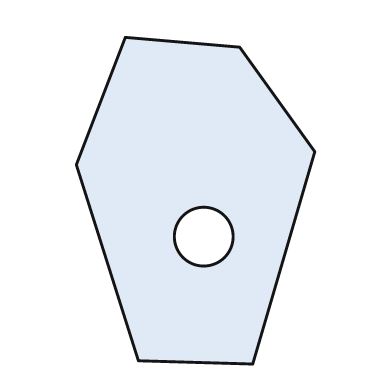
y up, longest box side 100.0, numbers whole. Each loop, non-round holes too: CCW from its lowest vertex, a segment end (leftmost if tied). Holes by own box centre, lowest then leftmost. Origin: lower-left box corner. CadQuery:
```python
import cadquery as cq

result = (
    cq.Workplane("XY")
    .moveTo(54.0, 0.0)
    .lineTo(73.0, 65.0)
    .lineTo(50.0, 97.0)
    .lineTo(15.0, 100.0)
    .lineTo(0.0, 61.0)
    .lineTo(19.0, 1.0)
    .close()
    .moveTo(39.0, 39.0)
    .circle(9.0)
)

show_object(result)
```